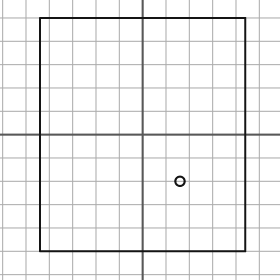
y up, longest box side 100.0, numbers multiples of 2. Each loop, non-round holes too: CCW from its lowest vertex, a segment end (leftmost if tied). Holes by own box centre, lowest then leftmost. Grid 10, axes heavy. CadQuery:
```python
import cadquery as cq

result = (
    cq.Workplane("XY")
    .moveTo(-44.0, -50.0)
    .lineTo(44.0, -50.0)
    .lineTo(44.0, 50.0)
    .lineTo(-44.0, 50.0)
    .close()
    .moveTo(16.0, -20.0)
    .circle(2.0)
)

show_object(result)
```